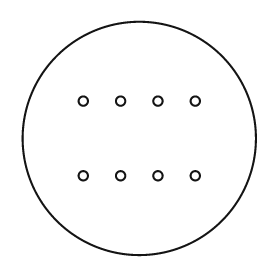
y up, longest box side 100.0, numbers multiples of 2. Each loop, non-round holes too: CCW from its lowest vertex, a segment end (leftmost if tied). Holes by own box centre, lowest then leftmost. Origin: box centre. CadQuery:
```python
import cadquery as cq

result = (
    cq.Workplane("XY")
    .moveTo(0.0, 0.0)
    .circle(50.0)
    .moveTo(-24.0, -16.0)
    .circle(2.0)
    .moveTo(-8.0, -16.0)
    .circle(2.0)
    .moveTo(8.0, -16.0)
    .circle(2.0)
    .moveTo(24.0, -16.0)
    .circle(2.0)
    .moveTo(-24.0, 16.0)
    .circle(2.0)
    .moveTo(-8.0, 16.0)
    .circle(2.0)
    .moveTo(8.0, 16.0)
    .circle(2.0)
    .moveTo(24.0, 16.0)
    .circle(2.0)
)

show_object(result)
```